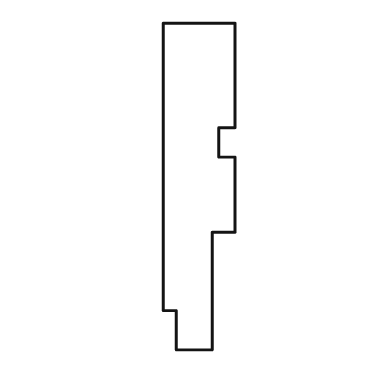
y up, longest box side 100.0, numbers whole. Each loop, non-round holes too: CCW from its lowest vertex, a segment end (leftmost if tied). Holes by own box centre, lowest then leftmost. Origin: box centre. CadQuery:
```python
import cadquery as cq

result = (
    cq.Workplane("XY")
    .moveTo(-7.0, -50.0)
    .lineTo(4.0, -50.0)
    .lineTo(4.0, -14.0)
    .lineTo(11.0, -14.0)
    .lineTo(11.0, 9.0)
    .lineTo(6.0, 9.0)
    .lineTo(6.0, 18.0)
    .lineTo(11.0, 18.0)
    .lineTo(11.0, 50.0)
    .lineTo(-11.0, 50.0)
    .lineTo(-11.0, -38.0)
    .lineTo(-7.0, -38.0)
    .close()
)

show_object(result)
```